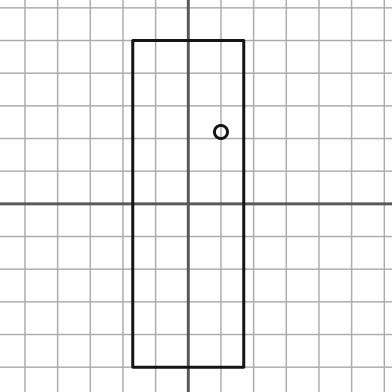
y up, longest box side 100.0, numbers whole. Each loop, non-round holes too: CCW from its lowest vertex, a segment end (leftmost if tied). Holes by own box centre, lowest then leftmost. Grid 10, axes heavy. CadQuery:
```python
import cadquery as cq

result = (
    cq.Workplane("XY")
    .moveTo(-17.0, -50.0)
    .lineTo(17.0, -50.0)
    .lineTo(17.0, 50.0)
    .lineTo(-17.0, 50.0)
    .close()
    .moveTo(10.0, 22.0)
    .circle(2.0)
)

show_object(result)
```